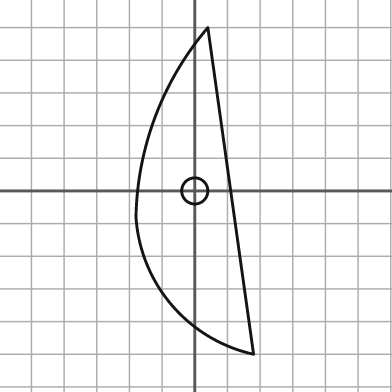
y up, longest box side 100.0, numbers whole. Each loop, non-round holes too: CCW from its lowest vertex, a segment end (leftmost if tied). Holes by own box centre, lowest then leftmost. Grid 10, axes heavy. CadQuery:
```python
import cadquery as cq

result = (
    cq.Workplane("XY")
    .moveTo(18.0, -50.0)
    .lineTo(4.0, 50.0)
    .threePointArc((-12.0, 23.0), (-18.0, -8.0))
    .threePointArc((-7.0, -35.0), (18.0, -50.0))
    .close()
    .moveTo(0.0, 0.0)
    .circle(4.0)
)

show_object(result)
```